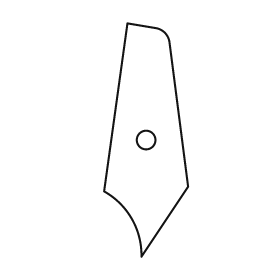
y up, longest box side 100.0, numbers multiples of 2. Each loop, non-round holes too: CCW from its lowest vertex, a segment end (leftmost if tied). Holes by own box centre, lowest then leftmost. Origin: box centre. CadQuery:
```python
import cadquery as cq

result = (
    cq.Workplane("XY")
    .moveTo(-2.0, -50.0)
    .lineTo(18.0, -20.0)
    .lineTo(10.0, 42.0)
    .threePointArc((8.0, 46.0), (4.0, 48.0))
    .lineTo(-8.0, 50.0)
    .lineTo(-18.0, -22.0)
    .threePointArc((-6.0, -34.0), (-2.0, -50.0))
    .close()
    .moveTo(0.0, 0.0)
    .circle(4.0)
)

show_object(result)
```